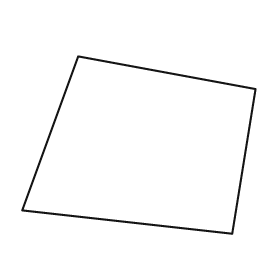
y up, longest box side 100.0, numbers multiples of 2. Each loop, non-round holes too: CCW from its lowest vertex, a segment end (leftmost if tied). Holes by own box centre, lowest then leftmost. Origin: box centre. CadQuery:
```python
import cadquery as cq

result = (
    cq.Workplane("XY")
    .moveTo(40.0, -38.0)
    .lineTo(50.0, 24.0)
    .lineTo(-26.0, 38.0)
    .lineTo(-50.0, -28.0)
    .close()
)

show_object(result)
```